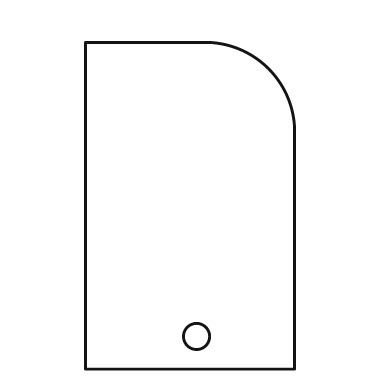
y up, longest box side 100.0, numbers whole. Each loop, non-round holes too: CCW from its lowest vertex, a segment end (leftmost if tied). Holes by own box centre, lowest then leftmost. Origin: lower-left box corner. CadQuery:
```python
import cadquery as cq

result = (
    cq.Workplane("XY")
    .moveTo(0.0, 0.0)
    .lineTo(64.0, 0.0)
    .lineTo(64.0, 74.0)
    .threePointArc((56.0, 92.0), (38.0, 100.0))
    .lineTo(0.0, 100.0)
    .close()
    .moveTo(34.0, 10.0)
    .circle(4.0)
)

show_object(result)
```